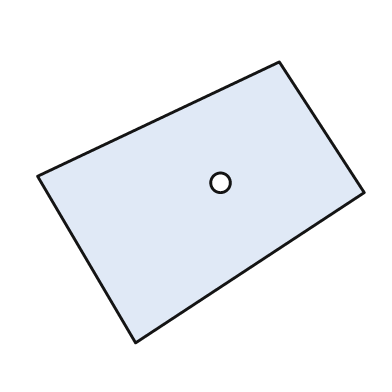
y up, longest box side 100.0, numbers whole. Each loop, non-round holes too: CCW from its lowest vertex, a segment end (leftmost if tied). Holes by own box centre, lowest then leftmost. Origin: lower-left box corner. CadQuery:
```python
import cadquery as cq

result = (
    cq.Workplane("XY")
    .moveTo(30.0, 0.0)
    .lineTo(100.0, 46.0)
    .lineTo(74.0, 86.0)
    .lineTo(0.0, 51.0)
    .close()
    .moveTo(56.0, 49.0)
    .circle(3.0)
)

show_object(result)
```